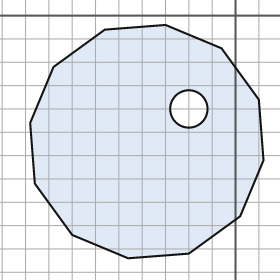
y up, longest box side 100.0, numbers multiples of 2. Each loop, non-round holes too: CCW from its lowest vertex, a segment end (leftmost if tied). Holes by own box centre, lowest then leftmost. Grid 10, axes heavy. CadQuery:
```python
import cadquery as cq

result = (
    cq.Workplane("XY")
    .moveTo(-46.0, -104.0)
    .lineTo(-20.0, -102.0)
    .lineTo(2.0, -86.0)
    .lineTo(12.0, -62.0)
    .lineTo(10.0, -36.0)
    .lineTo(-6.0, -14.0)
    .lineTo(-30.0, -4.0)
    .lineTo(-56.0, -6.0)
    .lineTo(-78.0, -22.0)
    .lineTo(-88.0, -46.0)
    .lineTo(-86.0, -72.0)
    .lineTo(-70.0, -94.0)
    .close()
    .moveTo(-20.0, -40.0)
    .circle(8.0)
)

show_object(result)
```